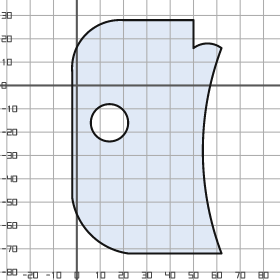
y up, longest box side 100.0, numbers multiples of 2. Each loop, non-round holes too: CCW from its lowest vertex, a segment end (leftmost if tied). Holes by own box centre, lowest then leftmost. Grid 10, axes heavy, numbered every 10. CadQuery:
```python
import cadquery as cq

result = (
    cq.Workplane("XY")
    .moveTo(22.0, -72.0)
    .lineTo(62.0, -72.0)
    .threePointArc((54.0, -28.0), (62.0, 16.0))
    .threePointArc((56.0, 18.0), (50.0, 16.0))
    .lineTo(50.0, 28.0)
    .lineTo(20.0, 28.0)
    .threePointArc((4.0, 22.0), (-2.0, 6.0))
    .lineTo(-2.0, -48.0)
    .threePointArc((6.0, -64.0), (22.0, -72.0))
    .close()
    .moveTo(14.0, -16.0)
    .circle(8.0)
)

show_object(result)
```